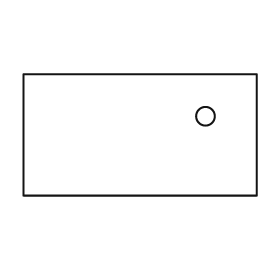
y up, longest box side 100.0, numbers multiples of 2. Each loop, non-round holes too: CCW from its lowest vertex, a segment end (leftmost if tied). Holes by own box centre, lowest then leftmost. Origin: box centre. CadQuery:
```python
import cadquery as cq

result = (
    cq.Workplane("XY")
    .moveTo(-50.0, -26.0)
    .lineTo(50.0, -26.0)
    .lineTo(50.0, 26.0)
    .lineTo(-50.0, 26.0)
    .close()
    .moveTo(28.0, 8.0)
    .circle(4.0)
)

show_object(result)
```